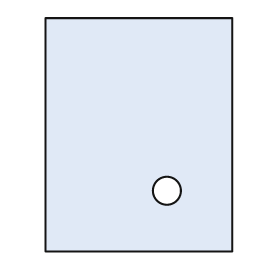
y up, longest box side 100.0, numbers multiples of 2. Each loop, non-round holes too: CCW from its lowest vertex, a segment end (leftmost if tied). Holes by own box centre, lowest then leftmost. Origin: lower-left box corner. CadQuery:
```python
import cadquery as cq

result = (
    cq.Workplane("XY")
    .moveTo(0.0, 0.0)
    .lineTo(80.0, 0.0)
    .lineTo(80.0, 100.0)
    .lineTo(0.0, 100.0)
    .close()
    .moveTo(52.0, 26.0)
    .circle(6.0)
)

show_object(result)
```